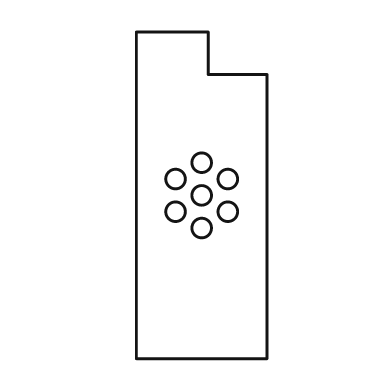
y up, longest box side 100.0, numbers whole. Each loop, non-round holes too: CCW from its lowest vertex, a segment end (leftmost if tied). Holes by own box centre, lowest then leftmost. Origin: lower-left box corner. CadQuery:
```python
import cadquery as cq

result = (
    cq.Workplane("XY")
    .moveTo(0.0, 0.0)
    .lineTo(40.0, 0.0)
    .lineTo(40.0, 87.0)
    .lineTo(22.0, 87.0)
    .lineTo(22.0, 100.0)
    .lineTo(0.0, 100.0)
    .close()
    .moveTo(20.0, 40.0)
    .circle(3.0)
    .moveTo(12.0, 45.0)
    .circle(3.0)
    .moveTo(28.0, 45.0)
    .circle(3.0)
    .moveTo(20.0, 50.0)
    .circle(3.0)
    .moveTo(12.0, 55.0)
    .circle(3.0)
    .moveTo(28.0, 55.0)
    .circle(3.0)
    .moveTo(20.0, 60.0)
    .circle(3.0)
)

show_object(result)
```